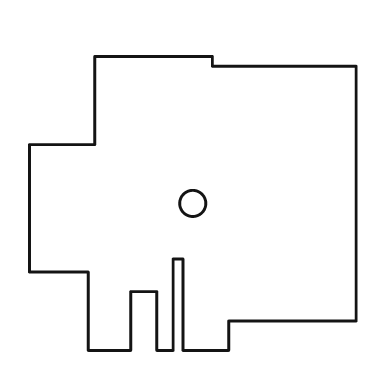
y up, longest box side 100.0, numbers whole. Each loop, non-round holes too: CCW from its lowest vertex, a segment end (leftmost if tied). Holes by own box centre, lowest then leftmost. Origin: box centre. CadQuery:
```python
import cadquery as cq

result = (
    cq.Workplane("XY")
    .moveTo(-32.0, -45.0)
    .lineTo(-19.0, -45.0)
    .lineTo(-19.0, -27.0)
    .lineTo(-11.0, -27.0)
    .lineTo(-11.0, -45.0)
    .lineTo(-6.0, -45.0)
    .lineTo(-6.0, -17.0)
    .lineTo(-3.0, -17.0)
    .lineTo(-3.0, -45.0)
    .lineTo(11.0, -45.0)
    .lineTo(11.0, -36.0)
    .lineTo(50.0, -36.0)
    .lineTo(50.0, 42.0)
    .lineTo(6.0, 42.0)
    .lineTo(6.0, 45.0)
    .lineTo(-30.0, 45.0)
    .lineTo(-30.0, 18.0)
    .lineTo(-50.0, 18.0)
    .lineTo(-50.0, -21.0)
    .lineTo(-32.0, -21.0)
    .close()
    .moveTo(0.0, 0.0)
    .circle(4.0)
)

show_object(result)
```